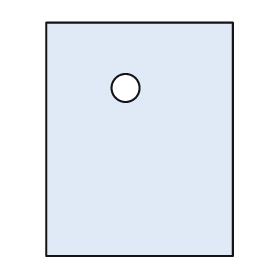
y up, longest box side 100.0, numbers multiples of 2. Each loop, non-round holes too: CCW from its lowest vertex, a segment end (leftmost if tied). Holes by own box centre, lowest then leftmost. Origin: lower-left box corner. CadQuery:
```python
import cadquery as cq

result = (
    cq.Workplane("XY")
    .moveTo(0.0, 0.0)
    .lineTo(80.0, 0.0)
    .lineTo(80.0, 100.0)
    .lineTo(0.0, 100.0)
    .close()
    .moveTo(34.0, 72.0)
    .circle(6.0)
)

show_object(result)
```